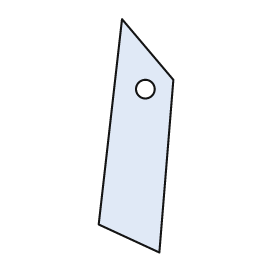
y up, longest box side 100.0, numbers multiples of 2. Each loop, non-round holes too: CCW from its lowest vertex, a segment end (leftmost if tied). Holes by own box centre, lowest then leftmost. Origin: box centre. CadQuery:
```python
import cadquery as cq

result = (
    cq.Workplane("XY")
    .moveTo(10.0, -50.0)
    .lineTo(16.0, 24.0)
    .lineTo(-6.0, 50.0)
    .lineTo(-16.0, -38.0)
    .close()
    .moveTo(4.0, 20.0)
    .circle(4.0)
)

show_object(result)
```